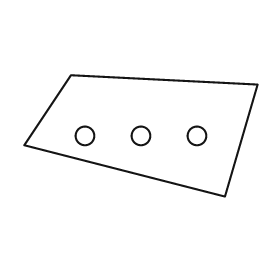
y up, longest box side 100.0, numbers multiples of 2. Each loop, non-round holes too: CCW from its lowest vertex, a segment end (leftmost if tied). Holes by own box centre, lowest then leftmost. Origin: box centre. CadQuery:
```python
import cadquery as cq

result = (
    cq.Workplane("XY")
    .moveTo(36.0, -26.0)
    .lineTo(50.0, 22.0)
    .lineTo(-30.0, 26.0)
    .lineTo(-50.0, -4.0)
    .close()
    .moveTo(-24.0, 0.0)
    .circle(4.0)
    .moveTo(0.0, 0.0)
    .circle(4.0)
    .moveTo(24.0, 0.0)
    .circle(4.0)
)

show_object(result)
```